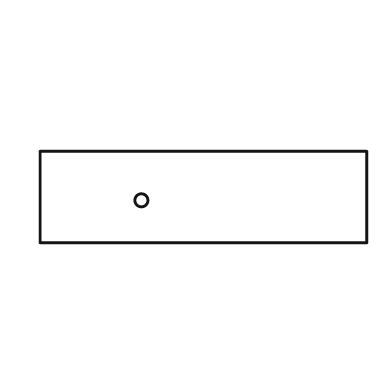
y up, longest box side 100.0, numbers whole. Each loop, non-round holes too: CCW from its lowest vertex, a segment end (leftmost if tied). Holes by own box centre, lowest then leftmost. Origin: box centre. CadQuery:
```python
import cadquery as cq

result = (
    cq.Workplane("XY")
    .moveTo(-50.0, -14.0)
    .lineTo(50.0, -14.0)
    .lineTo(50.0, 14.0)
    .lineTo(-50.0, 14.0)
    .close()
    .moveTo(-19.0, -1.0)
    .circle(2.0)
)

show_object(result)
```